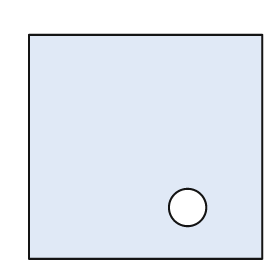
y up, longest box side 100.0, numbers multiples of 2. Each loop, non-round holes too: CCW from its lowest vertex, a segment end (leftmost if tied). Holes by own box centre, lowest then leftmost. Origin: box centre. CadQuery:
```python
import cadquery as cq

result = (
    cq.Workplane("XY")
    .moveTo(-50.0, -48.0)
    .lineTo(50.0, -48.0)
    .lineTo(50.0, 48.0)
    .lineTo(-50.0, 48.0)
    .close()
    .moveTo(18.0, -26.0)
    .circle(8.0)
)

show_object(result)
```